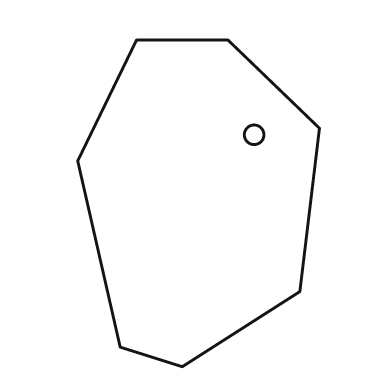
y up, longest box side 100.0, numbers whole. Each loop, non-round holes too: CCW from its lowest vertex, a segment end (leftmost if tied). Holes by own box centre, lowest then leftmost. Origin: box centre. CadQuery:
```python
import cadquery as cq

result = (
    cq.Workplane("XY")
    .moveTo(-5.0, -50.0)
    .lineTo(31.0, -27.0)
    .lineTo(37.0, 23.0)
    .lineTo(9.0, 50.0)
    .lineTo(-19.0, 50.0)
    .lineTo(-37.0, 13.0)
    .lineTo(-24.0, -44.0)
    .close()
    .moveTo(17.0, 21.0)
    .circle(3.0)
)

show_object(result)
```